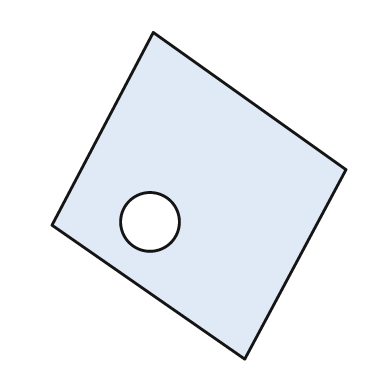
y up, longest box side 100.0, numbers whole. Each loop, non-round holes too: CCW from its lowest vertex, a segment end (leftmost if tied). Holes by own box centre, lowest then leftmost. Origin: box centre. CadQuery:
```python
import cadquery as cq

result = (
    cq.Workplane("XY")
    .moveTo(14.0, -50.0)
    .lineTo(45.0, 8.0)
    .lineTo(-14.0, 50.0)
    .lineTo(-45.0, -9.0)
    .close()
    .moveTo(-15.0, -8.0)
    .circle(9.0)
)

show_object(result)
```